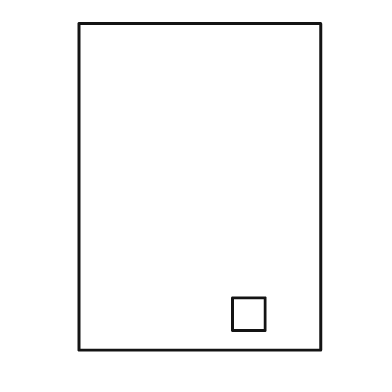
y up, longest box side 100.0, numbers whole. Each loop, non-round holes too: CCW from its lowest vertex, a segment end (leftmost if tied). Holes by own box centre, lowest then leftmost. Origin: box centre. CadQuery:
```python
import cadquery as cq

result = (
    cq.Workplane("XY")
    .moveTo(-37.0, -50.0)
    .lineTo(37.0, -50.0)
    .lineTo(37.0, 50.0)
    .lineTo(-37.0, 50.0)
    .close()
    .moveTo(10.0, -44.0)
    .lineTo(20.0, -44.0)
    .lineTo(20.0, -34.0)
    .lineTo(10.0, -34.0)
    .close()
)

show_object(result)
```